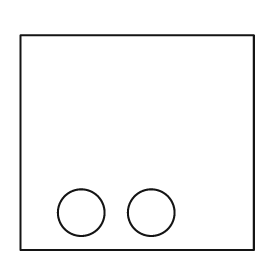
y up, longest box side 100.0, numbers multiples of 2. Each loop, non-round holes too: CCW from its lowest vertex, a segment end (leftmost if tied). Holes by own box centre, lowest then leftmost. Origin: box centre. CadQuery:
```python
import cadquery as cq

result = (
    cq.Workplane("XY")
    .moveTo(-50.0, -46.0)
    .lineTo(50.0, -46.0)
    .lineTo(50.0, 46.0)
    .lineTo(-50.0, 46.0)
    .close()
    .moveTo(-24.0, -30.0)
    .circle(10.0)
    .moveTo(6.0, -30.0)
    .circle(10.0)
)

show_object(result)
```